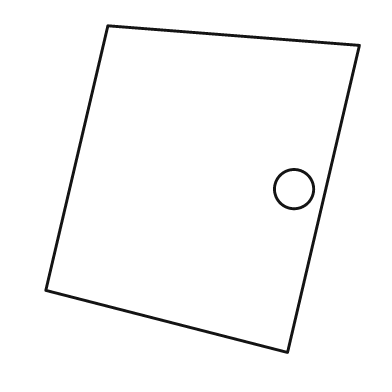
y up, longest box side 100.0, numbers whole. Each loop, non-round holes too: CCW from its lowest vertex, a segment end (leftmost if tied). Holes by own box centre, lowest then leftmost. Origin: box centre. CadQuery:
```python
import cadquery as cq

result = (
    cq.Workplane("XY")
    .moveTo(26.0, -50.0)
    .lineTo(48.0, 44.0)
    .lineTo(-29.0, 50.0)
    .lineTo(-48.0, -31.0)
    .close()
    .moveTo(28.0, 0.0)
    .circle(6.0)
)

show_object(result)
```